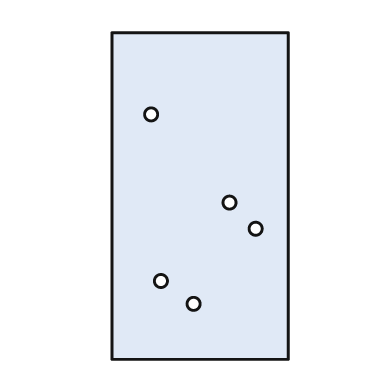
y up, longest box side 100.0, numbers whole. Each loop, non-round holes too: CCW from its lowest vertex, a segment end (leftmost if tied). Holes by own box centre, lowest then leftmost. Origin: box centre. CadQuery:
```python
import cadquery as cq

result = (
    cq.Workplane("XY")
    .moveTo(-27.0, -50.0)
    .lineTo(27.0, -50.0)
    .lineTo(27.0, 50.0)
    .lineTo(-27.0, 50.0)
    .close()
    .moveTo(-2.0, -33.0)
    .circle(2.0)
    .moveTo(-12.0, -26.0)
    .circle(2.0)
    .moveTo(17.0, -10.0)
    .circle(2.0)
    .moveTo(9.0, -2.0)
    .circle(2.0)
    .moveTo(-15.0, 25.0)
    .circle(2.0)
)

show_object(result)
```